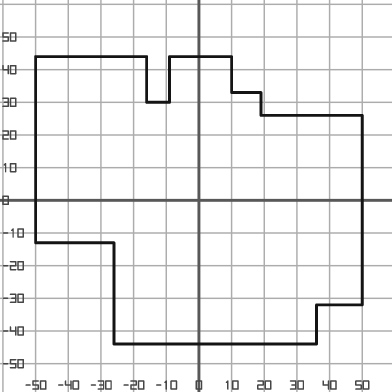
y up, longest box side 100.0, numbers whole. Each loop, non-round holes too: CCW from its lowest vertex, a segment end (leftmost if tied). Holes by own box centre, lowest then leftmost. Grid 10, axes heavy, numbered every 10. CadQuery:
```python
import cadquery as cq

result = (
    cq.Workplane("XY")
    .moveTo(-26.0, -44.0)
    .lineTo(36.0, -44.0)
    .lineTo(36.0, -32.0)
    .lineTo(50.0, -32.0)
    .lineTo(50.0, 26.0)
    .lineTo(19.0, 26.0)
    .lineTo(19.0, 33.0)
    .lineTo(10.0, 33.0)
    .lineTo(10.0, 44.0)
    .lineTo(-9.0, 44.0)
    .lineTo(-9.0, 30.0)
    .lineTo(-16.0, 30.0)
    .lineTo(-16.0, 44.0)
    .lineTo(-50.0, 44.0)
    .lineTo(-50.0, -13.0)
    .lineTo(-26.0, -13.0)
    .close()
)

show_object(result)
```